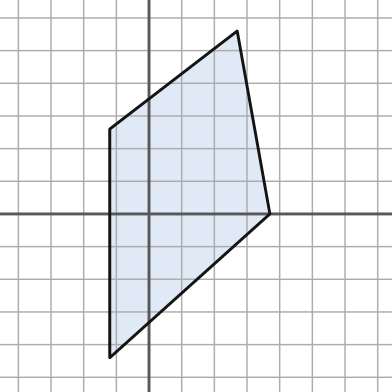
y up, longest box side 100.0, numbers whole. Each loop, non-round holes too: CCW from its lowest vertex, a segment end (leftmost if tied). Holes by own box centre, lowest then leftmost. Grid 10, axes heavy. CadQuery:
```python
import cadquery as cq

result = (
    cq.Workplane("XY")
    .moveTo(-12.0, -44.0)
    .lineTo(37.0, 0.0)
    .lineTo(27.0, 56.0)
    .lineTo(-12.0, 26.0)
    .close()
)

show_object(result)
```